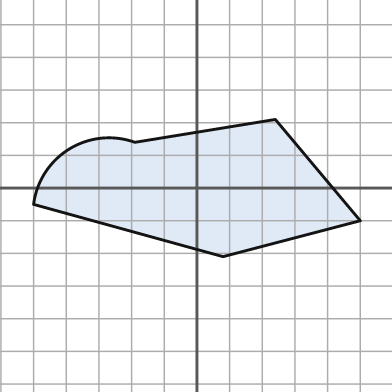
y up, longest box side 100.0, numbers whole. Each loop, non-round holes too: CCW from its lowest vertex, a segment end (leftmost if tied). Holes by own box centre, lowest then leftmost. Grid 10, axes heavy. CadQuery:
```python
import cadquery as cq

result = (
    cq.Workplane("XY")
    .moveTo(8.0, -21.0)
    .lineTo(50.0, -10.0)
    .lineTo(24.0, 21.0)
    .lineTo(-19.0, 14.0)
    .threePointArc((-39.0, 12.0), (-50.0, -5.0))
    .close()
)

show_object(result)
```